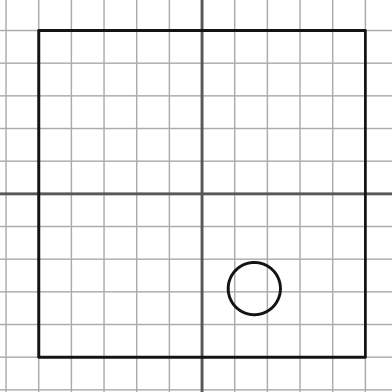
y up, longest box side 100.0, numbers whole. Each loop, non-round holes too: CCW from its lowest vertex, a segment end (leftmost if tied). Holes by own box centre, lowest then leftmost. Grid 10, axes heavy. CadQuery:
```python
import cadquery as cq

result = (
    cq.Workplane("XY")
    .moveTo(-50.0, -50.0)
    .lineTo(50.0, -50.0)
    .lineTo(50.0, 50.0)
    .lineTo(-50.0, 50.0)
    .close()
    .moveTo(16.0, -29.0)
    .circle(8.0)
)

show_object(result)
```